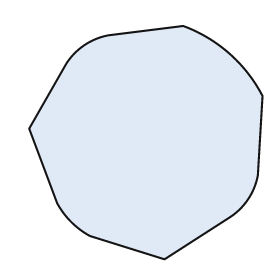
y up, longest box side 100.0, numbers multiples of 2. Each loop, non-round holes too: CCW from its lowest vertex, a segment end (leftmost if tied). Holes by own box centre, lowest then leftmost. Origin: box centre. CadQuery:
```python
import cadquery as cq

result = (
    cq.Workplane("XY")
    .moveTo(8.0, -50.0)
    .lineTo(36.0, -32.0)
    .threePointArc((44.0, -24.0), (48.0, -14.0))
    .lineTo(50.0, 20.0)
    .threePointArc((36.0, 38.0), (16.0, 50.0))
    .lineTo(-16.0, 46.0)
    .threePointArc((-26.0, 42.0), (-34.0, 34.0))
    .lineTo(-50.0, 6.0)
    .lineTo(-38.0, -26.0)
    .threePointArc((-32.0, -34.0), (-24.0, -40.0))
    .close()
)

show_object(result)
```